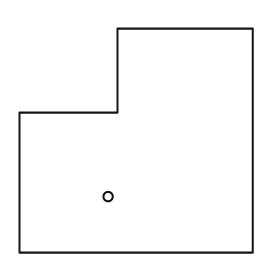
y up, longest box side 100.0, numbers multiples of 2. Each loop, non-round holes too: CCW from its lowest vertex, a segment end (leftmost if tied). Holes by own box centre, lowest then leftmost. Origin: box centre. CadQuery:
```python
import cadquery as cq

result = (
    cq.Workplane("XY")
    .moveTo(-50.0, -48.0)
    .lineTo(50.0, -48.0)
    .lineTo(50.0, 48.0)
    .lineTo(-8.0, 48.0)
    .lineTo(-8.0, 12.0)
    .lineTo(-50.0, 12.0)
    .close()
    .moveTo(-12.0, -24.0)
    .circle(2.0)
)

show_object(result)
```